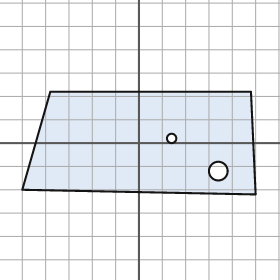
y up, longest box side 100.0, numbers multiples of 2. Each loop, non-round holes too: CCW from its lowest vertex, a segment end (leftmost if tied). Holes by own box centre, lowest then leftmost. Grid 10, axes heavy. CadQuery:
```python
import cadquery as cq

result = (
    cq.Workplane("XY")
    .moveTo(50.0, -22.0)
    .lineTo(48.0, 22.0)
    .lineTo(-38.0, 22.0)
    .lineTo(-50.0, -20.0)
    .close()
    .moveTo(34.0, -12.0)
    .circle(4.0)
    .moveTo(14.0, 2.0)
    .circle(2.0)
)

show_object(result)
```